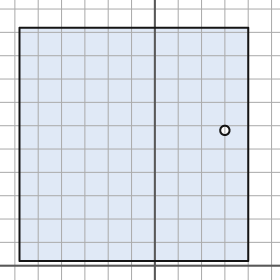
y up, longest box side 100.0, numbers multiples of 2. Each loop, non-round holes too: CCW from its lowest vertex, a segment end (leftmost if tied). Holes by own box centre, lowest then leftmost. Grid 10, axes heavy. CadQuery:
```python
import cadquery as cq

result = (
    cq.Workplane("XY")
    .moveTo(-58.0, 2.0)
    .lineTo(40.0, 2.0)
    .lineTo(40.0, 102.0)
    .lineTo(-58.0, 102.0)
    .close()
    .moveTo(30.0, 58.0)
    .circle(2.0)
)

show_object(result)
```